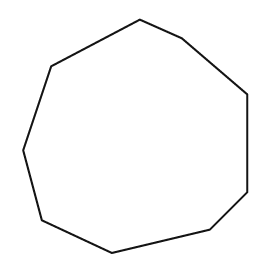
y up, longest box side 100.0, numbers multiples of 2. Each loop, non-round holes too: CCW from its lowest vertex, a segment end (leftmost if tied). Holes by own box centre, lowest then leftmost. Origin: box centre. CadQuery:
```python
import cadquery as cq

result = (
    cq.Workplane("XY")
    .moveTo(-10.0, -50.0)
    .lineTo(32.0, -40.0)
    .lineTo(48.0, -24.0)
    .lineTo(48.0, 18.0)
    .lineTo(20.0, 42.0)
    .lineTo(2.0, 50.0)
    .lineTo(-36.0, 30.0)
    .lineTo(-48.0, -6.0)
    .lineTo(-40.0, -36.0)
    .close()
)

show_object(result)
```